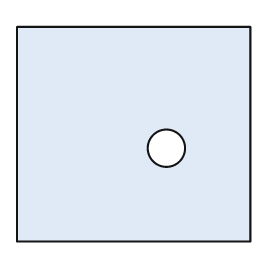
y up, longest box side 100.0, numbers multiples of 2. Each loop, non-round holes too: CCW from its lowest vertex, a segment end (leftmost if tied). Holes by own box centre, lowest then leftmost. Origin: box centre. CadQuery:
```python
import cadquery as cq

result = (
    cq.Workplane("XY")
    .moveTo(-50.0, -46.0)
    .lineTo(50.0, -46.0)
    .lineTo(50.0, 46.0)
    .lineTo(-50.0, 46.0)
    .close()
    .moveTo(14.0, -6.0)
    .circle(8.0)
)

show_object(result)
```